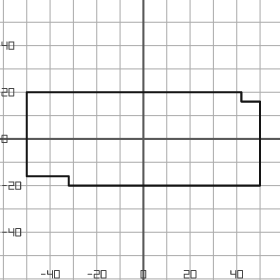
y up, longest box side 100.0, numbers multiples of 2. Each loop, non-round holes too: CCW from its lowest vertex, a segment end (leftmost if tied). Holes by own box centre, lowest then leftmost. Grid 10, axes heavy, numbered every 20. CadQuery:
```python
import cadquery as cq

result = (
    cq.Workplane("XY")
    .moveTo(-32.0, -20.0)
    .lineTo(50.0, -20.0)
    .lineTo(50.0, 16.0)
    .lineTo(42.0, 16.0)
    .lineTo(42.0, 20.0)
    .lineTo(-50.0, 20.0)
    .lineTo(-50.0, -16.0)
    .lineTo(-32.0, -16.0)
    .close()
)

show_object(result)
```